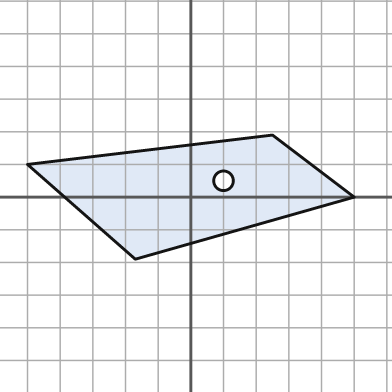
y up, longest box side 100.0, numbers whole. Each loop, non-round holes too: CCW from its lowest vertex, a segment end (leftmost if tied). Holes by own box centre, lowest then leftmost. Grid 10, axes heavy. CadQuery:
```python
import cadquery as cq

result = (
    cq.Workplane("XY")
    .moveTo(-17.0, -19.0)
    .lineTo(50.0, 0.0)
    .lineTo(25.0, 19.0)
    .lineTo(-50.0, 10.0)
    .close()
    .moveTo(10.0, 5.0)
    .circle(3.0)
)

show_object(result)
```